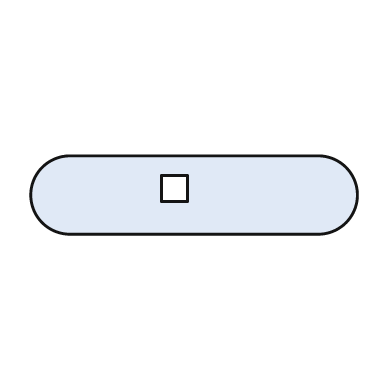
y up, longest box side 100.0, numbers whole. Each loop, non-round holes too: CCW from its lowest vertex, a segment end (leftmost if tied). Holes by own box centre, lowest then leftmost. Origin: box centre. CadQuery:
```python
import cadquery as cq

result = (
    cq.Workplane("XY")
    .moveTo(-38.0, -12.0)
    .lineTo(38.0, -12.0)
    .threePointArc((50.0, 0.0), (38.0, 12.0))
    .lineTo(-38.0, 12.0)
    .threePointArc((-50.0, 0.0), (-38.0, -12.0))
    .close()
    .moveTo(-10.0, -2.0)
    .lineTo(-2.0, -2.0)
    .lineTo(-2.0, 6.0)
    .lineTo(-10.0, 6.0)
    .close()
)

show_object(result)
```